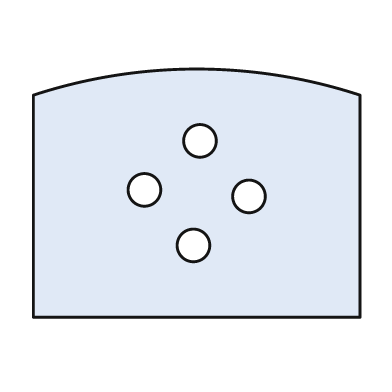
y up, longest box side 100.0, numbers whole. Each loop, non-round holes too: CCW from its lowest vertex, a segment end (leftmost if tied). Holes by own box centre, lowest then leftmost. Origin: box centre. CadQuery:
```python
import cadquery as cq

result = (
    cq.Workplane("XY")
    .moveTo(-50.0, -38.0)
    .lineTo(50.0, -38.0)
    .lineTo(50.0, 30.0)
    .threePointArc((0.0, 38.0), (-50.0, 30.0))
    .close()
    .moveTo(-1.0, -16.0)
    .circle(5.0)
    .moveTo(16.0, -1.0)
    .circle(5.0)
    .moveTo(-16.0, 1.0)
    .circle(5.0)
    .moveTo(1.0, 16.0)
    .circle(5.0)
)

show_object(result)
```